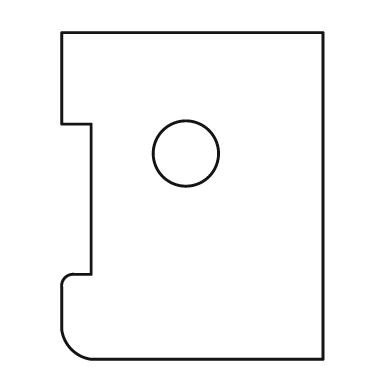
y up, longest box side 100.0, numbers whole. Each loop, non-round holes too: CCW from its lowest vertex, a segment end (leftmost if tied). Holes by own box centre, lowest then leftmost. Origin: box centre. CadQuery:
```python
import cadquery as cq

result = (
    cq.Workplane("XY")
    .moveTo(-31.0, -50.0)
    .lineTo(40.0, -50.0)
    .lineTo(40.0, 50.0)
    .lineTo(-40.0, 50.0)
    .lineTo(-40.0, 22.0)
    .lineTo(-31.0, 22.0)
    .lineTo(-31.0, -24.0)
    .lineTo(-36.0, -24.0)
    .threePointArc((-39.0, -25.0), (-40.0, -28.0))
    .lineTo(-40.0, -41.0)
    .threePointArc((-37.0, -47.0), (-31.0, -50.0))
    .close()
    .moveTo(-2.0, 13.0)
    .circle(10.0)
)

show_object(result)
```